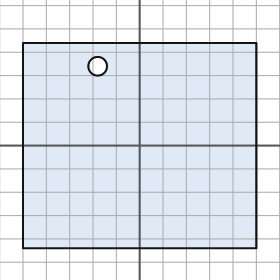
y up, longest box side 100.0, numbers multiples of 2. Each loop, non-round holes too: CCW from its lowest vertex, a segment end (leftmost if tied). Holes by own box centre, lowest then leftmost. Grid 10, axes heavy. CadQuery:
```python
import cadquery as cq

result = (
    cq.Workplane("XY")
    .moveTo(-50.0, -44.0)
    .lineTo(50.0, -44.0)
    .lineTo(50.0, 44.0)
    .lineTo(-50.0, 44.0)
    .close()
    .moveTo(-18.0, 34.0)
    .circle(4.0)
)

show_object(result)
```